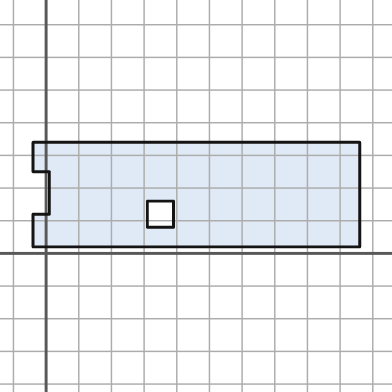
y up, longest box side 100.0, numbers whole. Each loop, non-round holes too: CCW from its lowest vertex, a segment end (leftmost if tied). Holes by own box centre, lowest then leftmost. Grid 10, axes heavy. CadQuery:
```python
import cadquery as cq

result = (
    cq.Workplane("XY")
    .moveTo(-4.0, 2.0)
    .lineTo(96.0, 2.0)
    .lineTo(96.0, 34.0)
    .lineTo(-4.0, 34.0)
    .lineTo(-4.0, 25.0)
    .lineTo(1.0, 25.0)
    .lineTo(1.0, 12.0)
    .lineTo(-4.0, 12.0)
    .close()
    .moveTo(31.0, 8.0)
    .lineTo(39.0, 8.0)
    .lineTo(39.0, 16.0)
    .lineTo(31.0, 16.0)
    .close()
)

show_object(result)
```